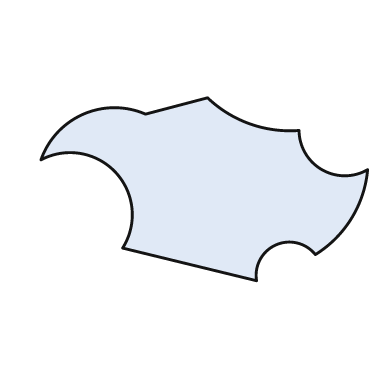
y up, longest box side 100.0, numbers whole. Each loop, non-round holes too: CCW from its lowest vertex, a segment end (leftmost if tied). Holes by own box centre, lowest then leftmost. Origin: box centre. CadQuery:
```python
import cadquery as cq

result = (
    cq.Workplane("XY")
    .moveTo(16.0, -28.0)
    .threePointArc((22.0, -17.0), (34.0, -20.0))
    .threePointArc((45.0, -9.0), (50.0, 6.0))
    .threePointArc((36.0, 6.0), (29.0, 18.0))
    .threePointArc((14.0, 20.0), (1.0, 28.0))
    .lineTo(-18.0, 23.0)
    .threePointArc((-37.0, 23.0), (-50.0, 9.0))
    .threePointArc((-27.0, 5.0), (-25.0, -18.0))
    .close()
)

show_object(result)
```